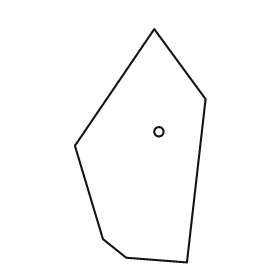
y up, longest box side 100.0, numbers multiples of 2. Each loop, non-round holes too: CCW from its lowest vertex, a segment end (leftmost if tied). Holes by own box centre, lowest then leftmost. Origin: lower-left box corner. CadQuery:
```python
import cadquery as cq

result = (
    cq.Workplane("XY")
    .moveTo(48.0, 0.0)
    .lineTo(56.0, 70.0)
    .lineTo(34.0, 100.0)
    .lineTo(0.0, 50.0)
    .lineTo(12.0, 10.0)
    .lineTo(22.0, 2.0)
    .close()
    .moveTo(36.0, 56.0)
    .circle(2.0)
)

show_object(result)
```